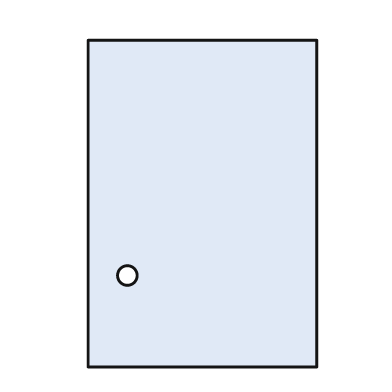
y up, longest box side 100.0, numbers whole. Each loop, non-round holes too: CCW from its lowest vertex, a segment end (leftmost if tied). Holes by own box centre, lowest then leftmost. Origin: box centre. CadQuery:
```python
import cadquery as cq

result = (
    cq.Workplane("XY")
    .moveTo(-35.0, -50.0)
    .lineTo(35.0, -50.0)
    .lineTo(35.0, 50.0)
    .lineTo(-35.0, 50.0)
    .close()
    .moveTo(-23.0, -22.0)
    .circle(3.0)
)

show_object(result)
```